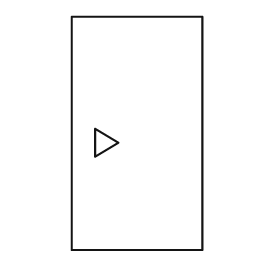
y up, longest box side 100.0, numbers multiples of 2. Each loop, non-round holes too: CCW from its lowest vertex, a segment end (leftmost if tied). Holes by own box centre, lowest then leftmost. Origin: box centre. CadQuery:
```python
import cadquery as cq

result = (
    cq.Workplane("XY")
    .moveTo(-28.0, -50.0)
    .lineTo(28.0, -50.0)
    .lineTo(28.0, 50.0)
    .lineTo(-28.0, 50.0)
    .close()
    .moveTo(-18.0, -10.0)
    .lineTo(-8.0, -4.0)
    .lineTo(-18.0, 2.0)
    .close()
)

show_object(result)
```